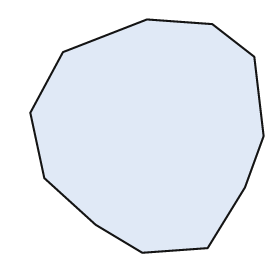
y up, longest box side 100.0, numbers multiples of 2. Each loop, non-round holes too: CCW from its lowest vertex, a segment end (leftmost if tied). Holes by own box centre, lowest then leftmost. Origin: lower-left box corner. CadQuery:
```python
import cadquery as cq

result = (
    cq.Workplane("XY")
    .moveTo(48.0, 0.0)
    .lineTo(76.0, 2.0)
    .lineTo(92.0, 28.0)
    .lineTo(100.0, 50.0)
    .lineTo(96.0, 84.0)
    .lineTo(78.0, 98.0)
    .lineTo(50.0, 100.0)
    .lineTo(14.0, 86.0)
    .lineTo(0.0, 60.0)
    .lineTo(6.0, 32.0)
    .lineTo(28.0, 12.0)
    .close()
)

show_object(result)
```